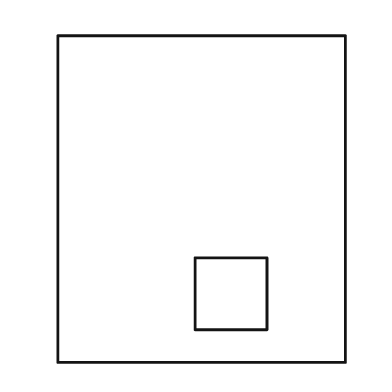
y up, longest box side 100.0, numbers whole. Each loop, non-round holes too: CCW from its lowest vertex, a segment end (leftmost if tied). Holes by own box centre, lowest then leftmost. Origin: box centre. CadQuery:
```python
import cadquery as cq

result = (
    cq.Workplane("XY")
    .moveTo(-44.0, -50.0)
    .lineTo(44.0, -50.0)
    .lineTo(44.0, 50.0)
    .lineTo(-44.0, 50.0)
    .close()
    .moveTo(-2.0, -40.0)
    .lineTo(20.0, -40.0)
    .lineTo(20.0, -18.0)
    .lineTo(-2.0, -18.0)
    .close()
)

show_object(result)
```